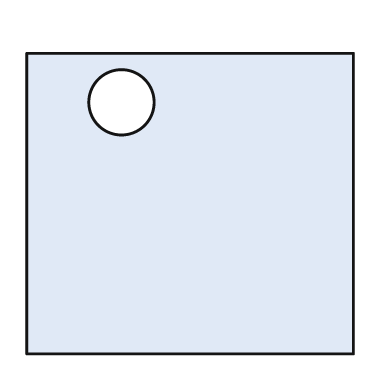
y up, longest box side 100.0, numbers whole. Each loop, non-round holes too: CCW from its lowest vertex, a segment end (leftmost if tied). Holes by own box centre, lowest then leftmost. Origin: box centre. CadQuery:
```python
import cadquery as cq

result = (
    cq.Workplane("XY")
    .moveTo(-50.0, -46.0)
    .lineTo(50.0, -46.0)
    .lineTo(50.0, 46.0)
    .lineTo(-50.0, 46.0)
    .close()
    .moveTo(-21.0, 31.0)
    .circle(10.0)
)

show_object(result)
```